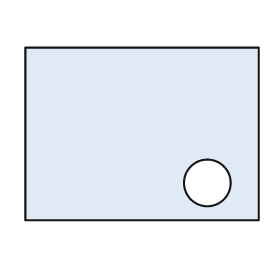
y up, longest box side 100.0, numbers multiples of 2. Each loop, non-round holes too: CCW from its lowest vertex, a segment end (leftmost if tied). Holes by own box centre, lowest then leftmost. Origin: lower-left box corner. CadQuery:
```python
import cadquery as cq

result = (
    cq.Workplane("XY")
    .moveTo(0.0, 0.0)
    .lineTo(100.0, 0.0)
    .lineTo(100.0, 74.0)
    .lineTo(0.0, 74.0)
    .close()
    .moveTo(78.0, 16.0)
    .circle(10.0)
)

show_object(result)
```